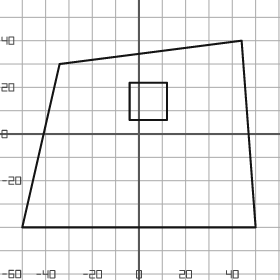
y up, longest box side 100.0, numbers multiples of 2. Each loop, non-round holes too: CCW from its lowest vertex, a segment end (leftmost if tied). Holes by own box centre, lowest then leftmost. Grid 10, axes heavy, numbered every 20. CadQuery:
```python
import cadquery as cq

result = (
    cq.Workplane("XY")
    .moveTo(-50.0, -40.0)
    .lineTo(50.0, -40.0)
    .lineTo(44.0, 40.0)
    .lineTo(-34.0, 30.0)
    .close()
    .moveTo(-4.0, 6.0)
    .lineTo(12.0, 6.0)
    .lineTo(12.0, 22.0)
    .lineTo(-4.0, 22.0)
    .close()
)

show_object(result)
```